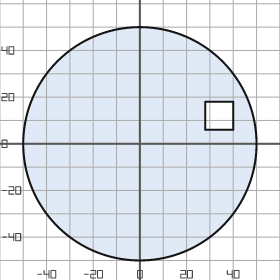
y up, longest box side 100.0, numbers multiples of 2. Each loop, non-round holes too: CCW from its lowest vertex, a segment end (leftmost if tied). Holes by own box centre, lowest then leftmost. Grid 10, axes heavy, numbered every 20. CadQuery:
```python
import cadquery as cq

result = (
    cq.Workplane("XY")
    .moveTo(0.0, 0.0)
    .circle(50.0)
    .moveTo(28.0, 6.0)
    .lineTo(40.0, 6.0)
    .lineTo(40.0, 18.0)
    .lineTo(28.0, 18.0)
    .close()
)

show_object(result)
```